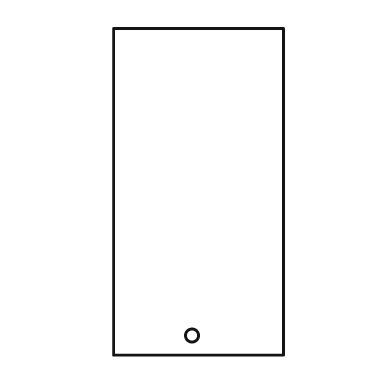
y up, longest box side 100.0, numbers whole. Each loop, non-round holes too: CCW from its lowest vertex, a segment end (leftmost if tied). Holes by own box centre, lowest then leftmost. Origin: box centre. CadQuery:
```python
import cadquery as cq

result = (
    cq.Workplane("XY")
    .moveTo(-26.0, -50.0)
    .lineTo(26.0, -50.0)
    .lineTo(26.0, 50.0)
    .lineTo(-26.0, 50.0)
    .close()
    .moveTo(-2.0, -44.0)
    .circle(2.0)
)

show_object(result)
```